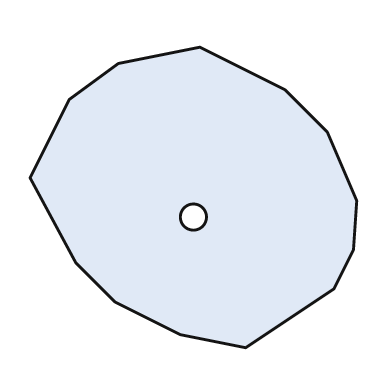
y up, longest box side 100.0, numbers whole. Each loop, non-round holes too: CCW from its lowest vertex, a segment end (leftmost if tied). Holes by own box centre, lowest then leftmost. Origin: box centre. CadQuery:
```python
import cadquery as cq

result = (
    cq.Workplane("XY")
    .moveTo(16.0, -46.0)
    .lineTo(43.0, -28.0)
    .lineTo(49.0, -16.0)
    .lineTo(50.0, -1.0)
    .lineTo(41.0, 20.0)
    .lineTo(28.0, 33.0)
    .lineTo(2.0, 46.0)
    .lineTo(-23.0, 41.0)
    .lineTo(-38.0, 30.0)
    .lineTo(-50.0, 6.0)
    .lineTo(-36.0, -20.0)
    .lineTo(-24.0, -32.0)
    .lineTo(-4.0, -42.0)
    .close()
    .moveTo(0.0, -6.0)
    .circle(4.0)
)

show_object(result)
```